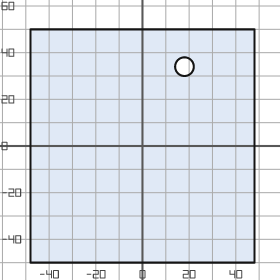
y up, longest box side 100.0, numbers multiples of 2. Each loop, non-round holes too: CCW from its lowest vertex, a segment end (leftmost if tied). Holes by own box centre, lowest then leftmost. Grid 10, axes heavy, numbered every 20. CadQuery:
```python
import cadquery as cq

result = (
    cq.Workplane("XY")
    .moveTo(-48.0, -50.0)
    .lineTo(48.0, -50.0)
    .lineTo(48.0, 50.0)
    .lineTo(-48.0, 50.0)
    .close()
    .moveTo(18.0, 34.0)
    .circle(4.0)
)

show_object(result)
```